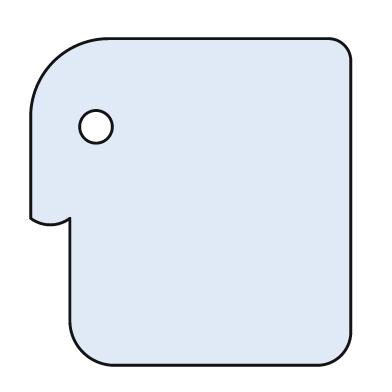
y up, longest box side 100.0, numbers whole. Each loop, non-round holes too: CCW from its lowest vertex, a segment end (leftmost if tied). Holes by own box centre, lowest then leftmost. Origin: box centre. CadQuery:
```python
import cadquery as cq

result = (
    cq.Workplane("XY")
    .moveTo(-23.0, -50.0)
    .lineTo(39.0, -50.0)
    .threePointArc((46.0, -47.0), (49.0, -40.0))
    .lineTo(49.0, 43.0)
    .threePointArc((47.0, 48.0), (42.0, 50.0))
    .lineTo(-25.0, 50.0)
    .threePointArc((-42.0, 43.0), (-49.0, 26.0))
    .lineTo(-49.0, -5.0)
    .threePointArc((-43.0, -7.0), (-37.0, -5.0))
    .lineTo(-37.0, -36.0)
    .threePointArc((-33.0, -46.0), (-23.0, -50.0))
    .close()
    .moveTo(-29.0, 23.0)
    .circle(5.0)
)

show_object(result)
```